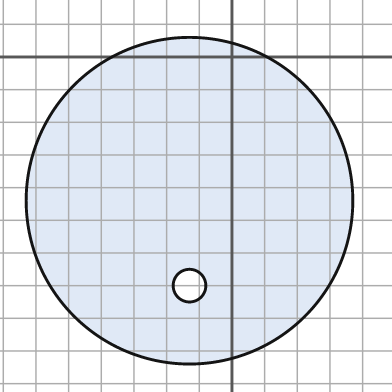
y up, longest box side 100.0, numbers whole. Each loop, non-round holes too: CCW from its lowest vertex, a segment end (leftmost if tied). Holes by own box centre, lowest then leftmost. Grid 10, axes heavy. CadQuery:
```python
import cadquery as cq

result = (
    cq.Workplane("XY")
    .moveTo(-13.0, -44.0)
    .circle(50.0)
    .moveTo(-13.0, -70.0)
    .circle(5.0)
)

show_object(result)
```